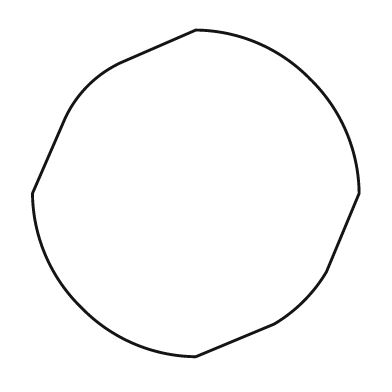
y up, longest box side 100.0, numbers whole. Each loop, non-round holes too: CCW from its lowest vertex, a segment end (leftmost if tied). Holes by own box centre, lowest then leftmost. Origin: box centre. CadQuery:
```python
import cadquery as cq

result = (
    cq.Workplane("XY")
    .moveTo(0.0, -50.0)
    .lineTo(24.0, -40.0)
    .threePointArc((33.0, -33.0), (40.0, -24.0))
    .lineTo(50.0, 0.0)
    .threePointArc((46.0, 19.0), (35.0, 35.0))
    .threePointArc((19.0, 46.0), (0.0, 50.0))
    .lineTo(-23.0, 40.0)
    .threePointArc((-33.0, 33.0), (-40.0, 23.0))
    .lineTo(-50.0, 0.0)
    .threePointArc((-46.0, -19.0), (-35.0, -35.0))
    .threePointArc((-19.0, -46.0), (0.0, -50.0))
    .close()
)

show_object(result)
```